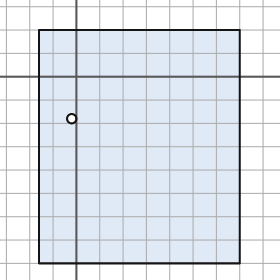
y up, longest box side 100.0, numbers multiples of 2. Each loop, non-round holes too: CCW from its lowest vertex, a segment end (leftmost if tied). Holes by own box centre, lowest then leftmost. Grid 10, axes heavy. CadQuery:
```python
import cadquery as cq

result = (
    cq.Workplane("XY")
    .moveTo(-16.0, -80.0)
    .lineTo(70.0, -80.0)
    .lineTo(70.0, 20.0)
    .lineTo(-16.0, 20.0)
    .close()
    .moveTo(-2.0, -18.0)
    .circle(2.0)
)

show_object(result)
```